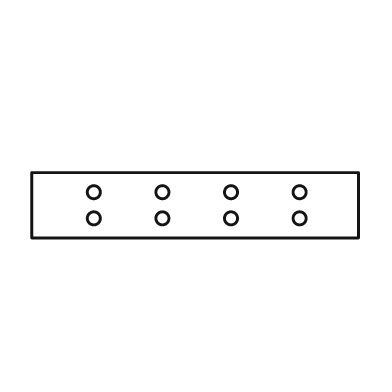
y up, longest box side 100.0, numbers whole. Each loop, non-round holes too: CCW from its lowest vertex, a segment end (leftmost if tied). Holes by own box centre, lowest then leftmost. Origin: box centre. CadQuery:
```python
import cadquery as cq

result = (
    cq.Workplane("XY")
    .moveTo(-50.0, -10.0)
    .lineTo(50.0, -10.0)
    .lineTo(50.0, 10.0)
    .lineTo(-50.0, 10.0)
    .close()
    .moveTo(-31.0, -4.0)
    .circle(2.0)
    .moveTo(-10.0, -4.0)
    .circle(2.0)
    .moveTo(11.0, -4.0)
    .circle(2.0)
    .moveTo(32.0, -4.0)
    .circle(2.0)
    .moveTo(-31.0, 4.0)
    .circle(2.0)
    .moveTo(-10.0, 4.0)
    .circle(2.0)
    .moveTo(11.0, 4.0)
    .circle(2.0)
    .moveTo(32.0, 4.0)
    .circle(2.0)
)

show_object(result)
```